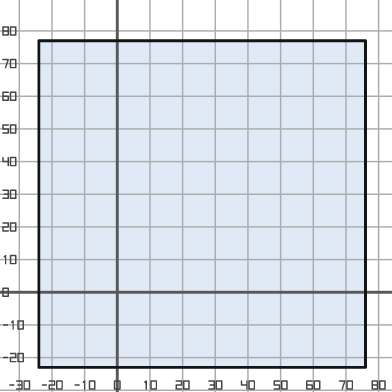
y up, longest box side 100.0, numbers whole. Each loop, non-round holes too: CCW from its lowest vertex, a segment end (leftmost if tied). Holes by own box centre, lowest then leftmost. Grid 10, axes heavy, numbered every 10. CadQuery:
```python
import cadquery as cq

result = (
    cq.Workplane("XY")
    .moveTo(-24.0, -23.0)
    .lineTo(76.0, -23.0)
    .lineTo(76.0, 77.0)
    .lineTo(-24.0, 77.0)
    .close()
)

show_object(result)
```